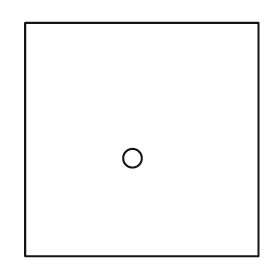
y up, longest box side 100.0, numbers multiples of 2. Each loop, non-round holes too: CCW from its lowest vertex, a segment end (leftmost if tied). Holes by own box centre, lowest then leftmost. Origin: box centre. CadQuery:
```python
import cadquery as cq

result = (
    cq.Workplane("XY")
    .moveTo(-50.0, -50.0)
    .lineTo(50.0, -50.0)
    .lineTo(50.0, 50.0)
    .lineTo(-50.0, 50.0)
    .close()
    .moveTo(-4.0, -8.0)
    .circle(4.0)
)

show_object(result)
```